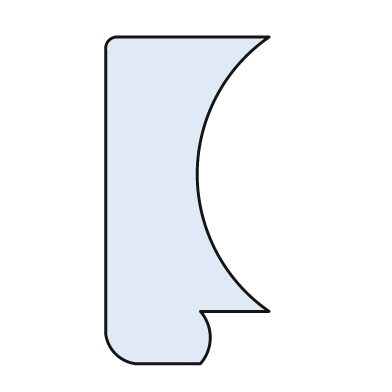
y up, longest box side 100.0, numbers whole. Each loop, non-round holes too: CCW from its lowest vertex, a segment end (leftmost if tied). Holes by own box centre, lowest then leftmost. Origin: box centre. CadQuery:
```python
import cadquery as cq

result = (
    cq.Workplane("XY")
    .moveTo(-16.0, -50.0)
    .lineTo(4.0, -50.0)
    .threePointArc((7.0, -42.0), (4.0, -34.0))
    .lineTo(25.0, -34.0)
    .threePointArc((3.0, 8.0), (25.0, 50.0))
    .lineTo(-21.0, 50.0)
    .threePointArc((-24.0, 49.0), (-25.0, 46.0))
    .lineTo(-25.0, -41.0)
    .threePointArc((-22.0, -47.0), (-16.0, -50.0))
    .close()
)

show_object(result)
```